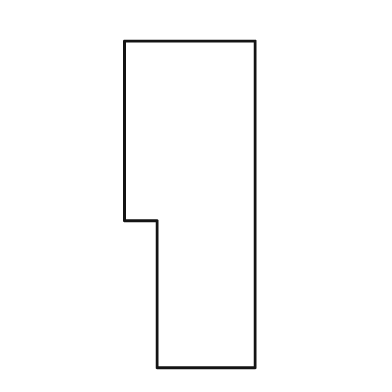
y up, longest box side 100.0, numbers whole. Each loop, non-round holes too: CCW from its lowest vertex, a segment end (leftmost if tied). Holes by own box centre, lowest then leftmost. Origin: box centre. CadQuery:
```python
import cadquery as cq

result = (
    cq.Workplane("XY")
    .moveTo(-10.0, -50.0)
    .lineTo(20.0, -50.0)
    .lineTo(20.0, 50.0)
    .lineTo(-20.0, 50.0)
    .lineTo(-20.0, -5.0)
    .lineTo(-10.0, -5.0)
    .close()
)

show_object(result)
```